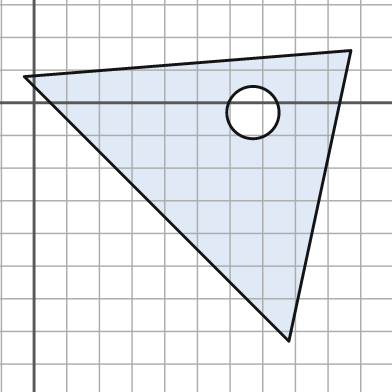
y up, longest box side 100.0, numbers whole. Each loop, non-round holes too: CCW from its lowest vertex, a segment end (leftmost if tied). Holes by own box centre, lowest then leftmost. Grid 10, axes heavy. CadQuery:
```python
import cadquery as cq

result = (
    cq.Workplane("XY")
    .moveTo(78.0, -73.0)
    .lineTo(97.0, 16.0)
    .lineTo(-3.0, 8.0)
    .close()
    .moveTo(67.0, -3.0)
    .circle(8.0)
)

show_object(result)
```